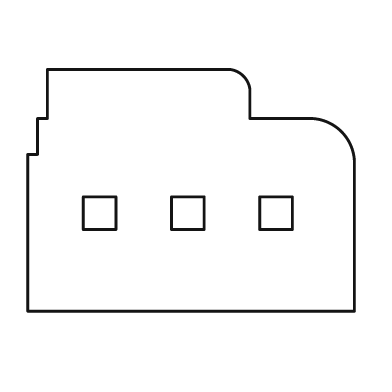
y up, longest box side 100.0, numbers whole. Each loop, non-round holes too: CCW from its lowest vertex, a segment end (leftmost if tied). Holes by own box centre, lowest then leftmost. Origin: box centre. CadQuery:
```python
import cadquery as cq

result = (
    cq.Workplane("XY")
    .moveTo(-50.0, -37.0)
    .lineTo(50.0, -37.0)
    .lineTo(50.0, 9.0)
    .threePointArc((46.0, 18.0), (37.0, 22.0))
    .lineTo(18.0, 22.0)
    .lineTo(18.0, 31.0)
    .threePointArc((16.0, 35.0), (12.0, 37.0))
    .lineTo(-44.0, 37.0)
    .lineTo(-44.0, 22.0)
    .lineTo(-47.0, 22.0)
    .lineTo(-47.0, 11.0)
    .lineTo(-50.0, 11.0)
    .close()
    .moveTo(-33.0, -12.0)
    .lineTo(-23.0, -12.0)
    .lineTo(-23.0, -2.0)
    .lineTo(-33.0, -2.0)
    .close()
    .moveTo(-6.0, -12.0)
    .lineTo(4.0, -12.0)
    .lineTo(4.0, -2.0)
    .lineTo(-6.0, -2.0)
    .close()
    .moveTo(21.0, -12.0)
    .lineTo(31.0, -12.0)
    .lineTo(31.0, -2.0)
    .lineTo(21.0, -2.0)
    .close()
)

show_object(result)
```